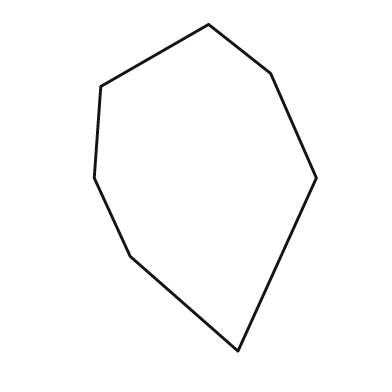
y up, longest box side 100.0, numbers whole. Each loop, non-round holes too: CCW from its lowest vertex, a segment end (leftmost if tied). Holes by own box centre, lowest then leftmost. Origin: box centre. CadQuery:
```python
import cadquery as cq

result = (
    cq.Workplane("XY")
    .moveTo(10.0, -50.0)
    .lineTo(34.0, 3.0)
    .lineTo(20.0, 35.0)
    .lineTo(1.0, 50.0)
    .lineTo(-32.0, 31.0)
    .lineTo(-34.0, 3.0)
    .lineTo(-23.0, -21.0)
    .close()
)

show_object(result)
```